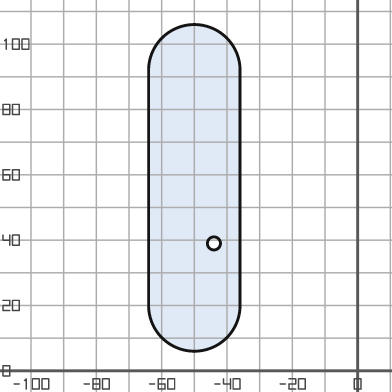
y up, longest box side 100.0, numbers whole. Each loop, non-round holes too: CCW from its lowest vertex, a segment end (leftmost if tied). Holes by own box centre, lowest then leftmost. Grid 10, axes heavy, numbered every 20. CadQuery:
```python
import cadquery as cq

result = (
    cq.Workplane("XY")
    .moveTo(-64.0, 20.0)
    .threePointArc((-50.0, 6.0), (-36.0, 20.0))
    .lineTo(-36.0, 92.0)
    .threePointArc((-50.0, 106.0), (-64.0, 92.0))
    .close()
    .moveTo(-44.0, 39.0)
    .circle(2.0)
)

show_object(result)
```